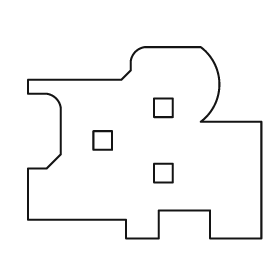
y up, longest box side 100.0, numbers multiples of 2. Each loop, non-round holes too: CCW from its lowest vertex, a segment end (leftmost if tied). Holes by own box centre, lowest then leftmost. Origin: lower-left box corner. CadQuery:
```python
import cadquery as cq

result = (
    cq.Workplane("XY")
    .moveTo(42.0, 0.0)
    .lineTo(56.0, 0.0)
    .lineTo(56.0, 12.0)
    .lineTo(78.0, 12.0)
    .lineTo(78.0, 0.0)
    .lineTo(100.0, 0.0)
    .lineTo(100.0, 50.0)
    .lineTo(74.0, 50.0)
    .threePointArc((82.0, 66.0), (74.0, 82.0))
    .lineTo(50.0, 82.0)
    .threePointArc((46.0, 80.0), (44.0, 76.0))
    .lineTo(44.0, 72.0)
    .lineTo(40.0, 68.0)
    .lineTo(0.0, 68.0)
    .lineTo(0.0, 62.0)
    .lineTo(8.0, 62.0)
    .threePointArc((12.0, 60.0), (14.0, 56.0))
    .lineTo(14.0, 36.0)
    .lineTo(8.0, 30.0)
    .lineTo(0.0, 30.0)
    .lineTo(0.0, 8.0)
    .lineTo(42.0, 8.0)
    .close()
    .moveTo(54.0, 24.0)
    .lineTo(62.0, 24.0)
    .lineTo(62.0, 32.0)
    .lineTo(54.0, 32.0)
    .close()
    .moveTo(28.0, 38.0)
    .lineTo(36.0, 38.0)
    .lineTo(36.0, 46.0)
    .lineTo(28.0, 46.0)
    .close()
    .moveTo(54.0, 52.0)
    .lineTo(62.0, 52.0)
    .lineTo(62.0, 60.0)
    .lineTo(54.0, 60.0)
    .close()
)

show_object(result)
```